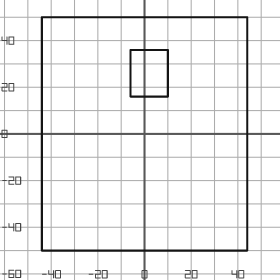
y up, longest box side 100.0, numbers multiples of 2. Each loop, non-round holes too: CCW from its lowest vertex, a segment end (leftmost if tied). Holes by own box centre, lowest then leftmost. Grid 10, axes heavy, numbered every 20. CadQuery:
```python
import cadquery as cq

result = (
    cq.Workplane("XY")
    .moveTo(-44.0, -50.0)
    .lineTo(44.0, -50.0)
    .lineTo(44.0, 50.0)
    .lineTo(-44.0, 50.0)
    .close()
    .moveTo(-6.0, 16.0)
    .lineTo(10.0, 16.0)
    .lineTo(10.0, 36.0)
    .lineTo(-6.0, 36.0)
    .close()
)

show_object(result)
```